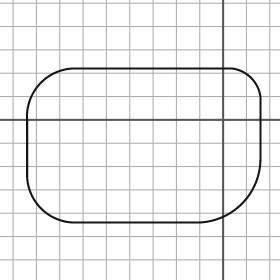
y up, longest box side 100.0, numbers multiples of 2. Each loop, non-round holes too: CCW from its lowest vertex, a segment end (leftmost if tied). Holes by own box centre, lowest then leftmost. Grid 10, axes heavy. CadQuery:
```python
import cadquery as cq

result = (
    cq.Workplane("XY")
    .moveTo(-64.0, -44.0)
    .lineTo(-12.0, -44.0)
    .threePointArc((8.0, -36.0), (16.0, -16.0))
    .lineTo(16.0, 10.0)
    .threePointArc((12.0, 18.0), (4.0, 22.0))
    .lineTo(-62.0, 22.0)
    .threePointArc((-78.0, 16.0), (-84.0, 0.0))
    .lineTo(-84.0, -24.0)
    .threePointArc((-78.0, -38.0), (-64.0, -44.0))
    .close()
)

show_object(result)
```